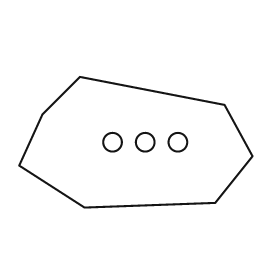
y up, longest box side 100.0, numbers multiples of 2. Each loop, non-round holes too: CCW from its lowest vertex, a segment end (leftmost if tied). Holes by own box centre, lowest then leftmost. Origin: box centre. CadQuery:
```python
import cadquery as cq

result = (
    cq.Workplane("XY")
    .moveTo(-22.0, -28.0)
    .lineTo(34.0, -26.0)
    .lineTo(50.0, -6.0)
    .lineTo(38.0, 16.0)
    .lineTo(-24.0, 28.0)
    .lineTo(-40.0, 12.0)
    .lineTo(-50.0, -10.0)
    .close()
    .moveTo(-10.0, 0.0)
    .circle(4.0)
    .moveTo(4.0, 0.0)
    .circle(4.0)
    .moveTo(18.0, 0.0)
    .circle(4.0)
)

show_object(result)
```